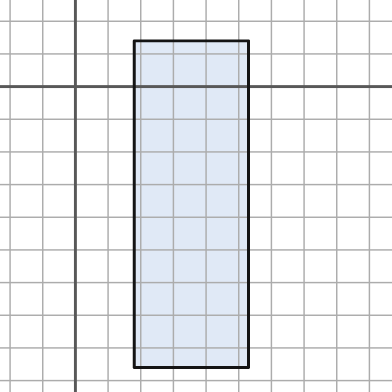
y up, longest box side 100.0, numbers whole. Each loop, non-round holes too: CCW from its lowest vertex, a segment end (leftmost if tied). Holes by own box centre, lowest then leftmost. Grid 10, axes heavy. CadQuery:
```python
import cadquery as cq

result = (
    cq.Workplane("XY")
    .moveTo(18.0, -86.0)
    .lineTo(53.0, -86.0)
    .lineTo(53.0, 14.0)
    .lineTo(18.0, 14.0)
    .close()
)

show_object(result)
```